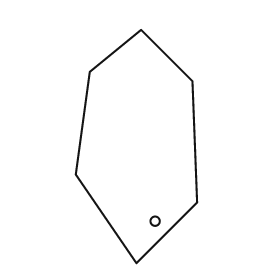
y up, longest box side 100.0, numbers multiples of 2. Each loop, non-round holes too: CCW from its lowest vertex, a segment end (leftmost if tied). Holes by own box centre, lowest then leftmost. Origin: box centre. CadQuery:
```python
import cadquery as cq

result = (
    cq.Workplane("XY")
    .moveTo(0.0, -50.0)
    .lineTo(26.0, -24.0)
    .lineTo(24.0, 28.0)
    .lineTo(2.0, 50.0)
    .lineTo(-20.0, 32.0)
    .lineTo(-26.0, -12.0)
    .close()
    .moveTo(8.0, -32.0)
    .circle(2.0)
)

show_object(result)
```